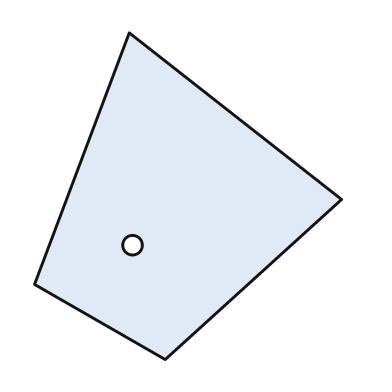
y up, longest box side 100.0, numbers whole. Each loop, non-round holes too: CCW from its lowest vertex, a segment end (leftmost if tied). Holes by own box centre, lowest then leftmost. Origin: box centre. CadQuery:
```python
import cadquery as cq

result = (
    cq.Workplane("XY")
    .moveTo(-7.0, -50.0)
    .lineTo(47.0, -1.0)
    .lineTo(-18.0, 50.0)
    .lineTo(-47.0, -27.0)
    .close()
    .moveTo(-17.0, -15.0)
    .circle(3.0)
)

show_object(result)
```